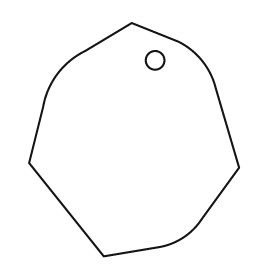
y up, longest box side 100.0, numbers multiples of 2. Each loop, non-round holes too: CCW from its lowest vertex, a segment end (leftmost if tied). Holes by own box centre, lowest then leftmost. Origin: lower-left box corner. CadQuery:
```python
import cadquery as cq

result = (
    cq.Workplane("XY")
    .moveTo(32.0, 0.0)
    .lineTo(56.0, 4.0)
    .threePointArc((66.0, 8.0), (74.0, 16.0))
    .lineTo(90.0, 38.0)
    .lineTo(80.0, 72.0)
    .threePointArc((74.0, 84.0), (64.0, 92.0))
    .lineTo(44.0, 100.0)
    .lineTo(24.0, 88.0)
    .threePointArc((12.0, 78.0), (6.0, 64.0))
    .lineTo(0.0, 40.0)
    .close()
    .moveTo(54.0, 84.0)
    .circle(4.0)
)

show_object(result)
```